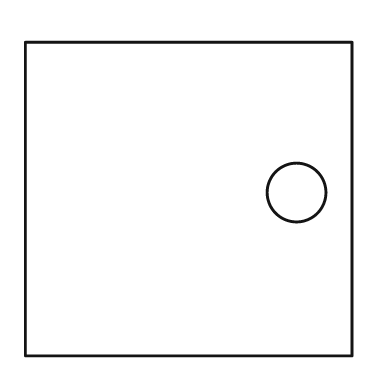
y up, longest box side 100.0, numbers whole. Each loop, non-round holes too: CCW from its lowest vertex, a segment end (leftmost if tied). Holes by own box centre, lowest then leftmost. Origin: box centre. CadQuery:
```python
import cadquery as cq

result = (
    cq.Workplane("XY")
    .moveTo(-50.0, -48.0)
    .lineTo(50.0, -48.0)
    .lineTo(50.0, 48.0)
    .lineTo(-50.0, 48.0)
    .close()
    .moveTo(33.0, 2.0)
    .circle(9.0)
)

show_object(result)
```